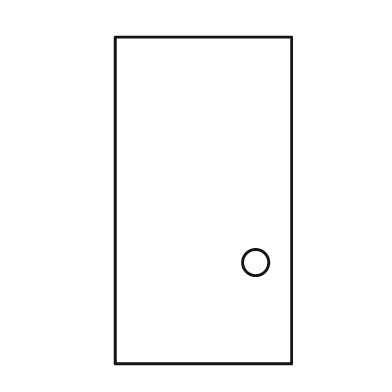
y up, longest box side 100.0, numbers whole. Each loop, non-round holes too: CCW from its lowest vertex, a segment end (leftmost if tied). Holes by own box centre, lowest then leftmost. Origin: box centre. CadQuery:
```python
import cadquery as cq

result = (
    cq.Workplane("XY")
    .moveTo(-27.0, -50.0)
    .lineTo(27.0, -50.0)
    .lineTo(27.0, 50.0)
    .lineTo(-27.0, 50.0)
    .close()
    .moveTo(16.0, -19.0)
    .circle(4.0)
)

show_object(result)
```